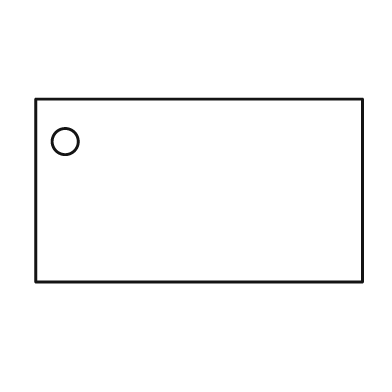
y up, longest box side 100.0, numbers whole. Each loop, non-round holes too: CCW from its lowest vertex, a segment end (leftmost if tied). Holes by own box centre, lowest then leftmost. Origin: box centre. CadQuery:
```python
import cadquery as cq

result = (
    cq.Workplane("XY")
    .moveTo(-50.0, -28.0)
    .lineTo(50.0, -28.0)
    .lineTo(50.0, 28.0)
    .lineTo(-50.0, 28.0)
    .close()
    .moveTo(-41.0, 15.0)
    .circle(4.0)
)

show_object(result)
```